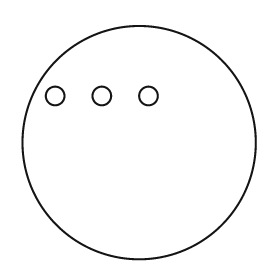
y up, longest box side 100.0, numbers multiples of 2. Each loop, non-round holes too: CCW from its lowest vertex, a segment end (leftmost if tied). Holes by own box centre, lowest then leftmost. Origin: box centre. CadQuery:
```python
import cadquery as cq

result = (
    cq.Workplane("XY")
    .moveTo(0.0, 0.0)
    .circle(50.0)
    .moveTo(-36.0, 20.0)
    .circle(4.0)
    .moveTo(-16.0, 20.0)
    .circle(4.0)
    .moveTo(4.0, 20.0)
    .circle(4.0)
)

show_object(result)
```